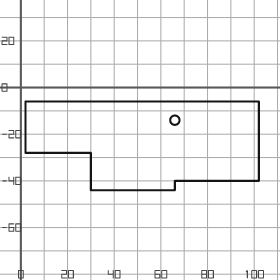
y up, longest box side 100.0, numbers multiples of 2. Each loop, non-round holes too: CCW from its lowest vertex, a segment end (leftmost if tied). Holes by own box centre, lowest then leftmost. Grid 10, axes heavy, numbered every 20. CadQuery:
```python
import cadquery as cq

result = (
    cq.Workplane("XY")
    .moveTo(30.0, -44.0)
    .lineTo(66.0, -44.0)
    .lineTo(66.0, -40.0)
    .lineTo(102.0, -40.0)
    .lineTo(102.0, -6.0)
    .lineTo(2.0, -6.0)
    .lineTo(2.0, -28.0)
    .lineTo(30.0, -28.0)
    .close()
    .moveTo(66.0, -14.0)
    .circle(2.0)
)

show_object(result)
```